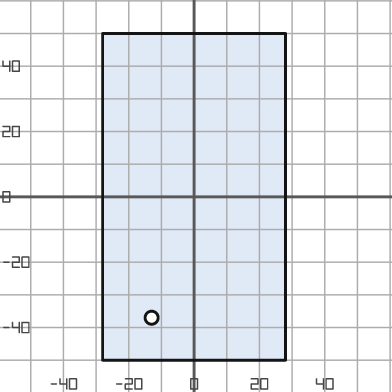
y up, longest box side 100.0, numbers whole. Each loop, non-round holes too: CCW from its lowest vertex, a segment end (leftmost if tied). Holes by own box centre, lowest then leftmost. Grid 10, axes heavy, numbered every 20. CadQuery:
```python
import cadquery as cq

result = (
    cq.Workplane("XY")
    .moveTo(-28.0, -50.0)
    .lineTo(28.0, -50.0)
    .lineTo(28.0, 50.0)
    .lineTo(-28.0, 50.0)
    .close()
    .moveTo(-13.0, -37.0)
    .circle(2.0)
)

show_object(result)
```